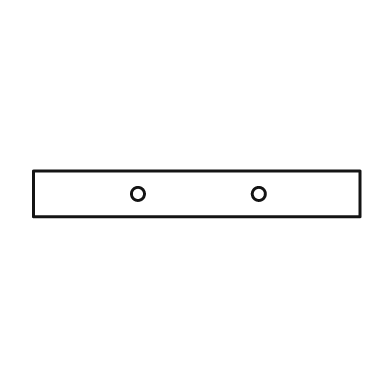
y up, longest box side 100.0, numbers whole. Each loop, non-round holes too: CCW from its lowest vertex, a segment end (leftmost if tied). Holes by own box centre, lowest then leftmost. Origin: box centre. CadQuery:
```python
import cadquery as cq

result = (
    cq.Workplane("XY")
    .moveTo(-50.0, -7.0)
    .lineTo(50.0, -7.0)
    .lineTo(50.0, 7.0)
    .lineTo(-50.0, 7.0)
    .close()
    .moveTo(-18.0, 0.0)
    .circle(2.0)
    .moveTo(19.0, 0.0)
    .circle(2.0)
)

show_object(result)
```